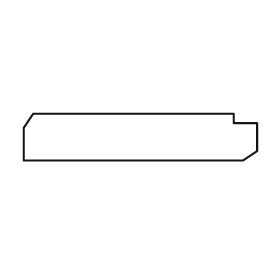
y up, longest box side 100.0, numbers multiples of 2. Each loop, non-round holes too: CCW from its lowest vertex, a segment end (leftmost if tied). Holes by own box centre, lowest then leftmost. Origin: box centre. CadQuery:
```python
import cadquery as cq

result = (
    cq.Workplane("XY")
    .moveTo(-50.0, -10.0)
    .lineTo(44.0, -10.0)
    .lineTo(50.0, -6.0)
    .lineTo(50.0, 6.0)
    .lineTo(40.0, 6.0)
    .lineTo(40.0, 10.0)
    .lineTo(-46.0, 10.0)
    .lineTo(-50.0, 4.0)
    .close()
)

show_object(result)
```